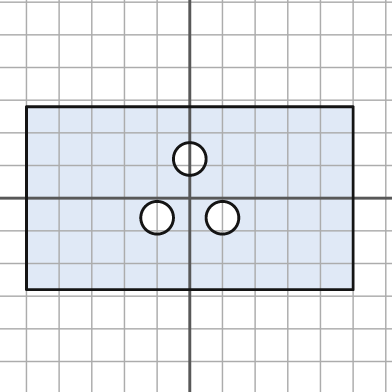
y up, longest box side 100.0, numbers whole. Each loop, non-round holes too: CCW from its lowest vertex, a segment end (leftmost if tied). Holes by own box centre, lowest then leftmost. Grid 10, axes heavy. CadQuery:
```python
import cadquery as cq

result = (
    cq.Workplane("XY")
    .moveTo(-50.0, -28.0)
    .lineTo(50.0, -28.0)
    .lineTo(50.0, 28.0)
    .lineTo(-50.0, 28.0)
    .close()
    .moveTo(-10.0, -6.0)
    .circle(5.0)
    .moveTo(10.0, -6.0)
    .circle(5.0)
    .moveTo(0.0, 12.0)
    .circle(5.0)
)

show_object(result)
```